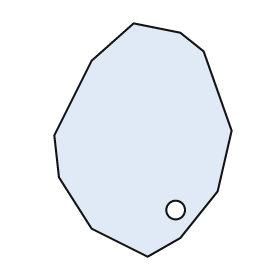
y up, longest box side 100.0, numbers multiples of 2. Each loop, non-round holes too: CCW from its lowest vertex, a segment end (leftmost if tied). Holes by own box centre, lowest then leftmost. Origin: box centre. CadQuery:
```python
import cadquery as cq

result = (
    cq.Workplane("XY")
    .moveTo(2.0, -50.0)
    .lineTo(16.0, -42.0)
    .lineTo(32.0, -22.0)
    .lineTo(38.0, 4.0)
    .lineTo(26.0, 38.0)
    .lineTo(16.0, 46.0)
    .lineTo(-4.0, 50.0)
    .lineTo(-22.0, 34.0)
    .lineTo(-38.0, 2.0)
    .lineTo(-36.0, -16.0)
    .lineTo(-22.0, -38.0)
    .close()
    .moveTo(14.0, -30.0)
    .circle(4.0)
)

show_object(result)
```